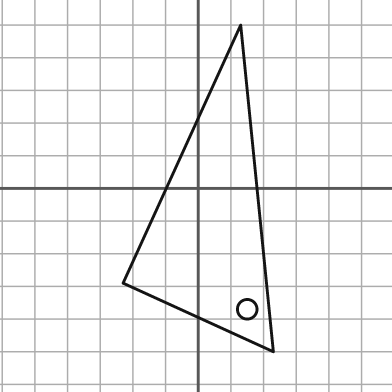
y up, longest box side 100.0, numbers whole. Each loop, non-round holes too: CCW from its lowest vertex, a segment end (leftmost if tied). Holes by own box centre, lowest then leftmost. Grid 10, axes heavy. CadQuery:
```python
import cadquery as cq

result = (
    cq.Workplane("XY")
    .moveTo(23.0, -50.0)
    .lineTo(13.0, 50.0)
    .lineTo(-23.0, -29.0)
    .close()
    .moveTo(15.0, -37.0)
    .circle(3.0)
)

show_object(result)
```